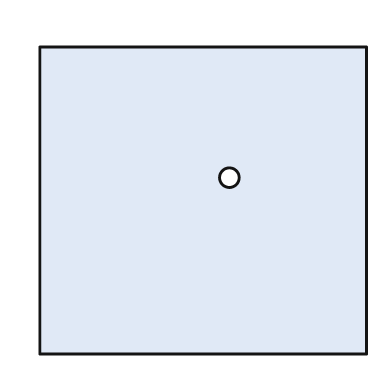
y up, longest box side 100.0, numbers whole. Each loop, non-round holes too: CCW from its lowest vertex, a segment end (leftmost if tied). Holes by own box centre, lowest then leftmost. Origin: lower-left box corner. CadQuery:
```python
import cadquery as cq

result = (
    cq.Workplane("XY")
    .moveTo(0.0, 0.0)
    .lineTo(100.0, 0.0)
    .lineTo(100.0, 94.0)
    .lineTo(0.0, 94.0)
    .close()
    .moveTo(58.0, 54.0)
    .circle(3.0)
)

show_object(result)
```